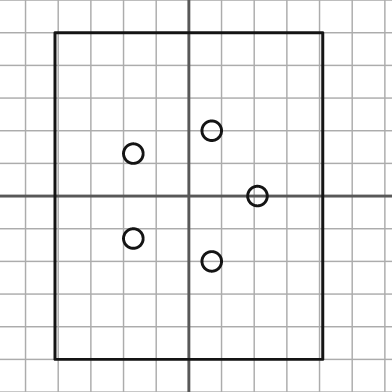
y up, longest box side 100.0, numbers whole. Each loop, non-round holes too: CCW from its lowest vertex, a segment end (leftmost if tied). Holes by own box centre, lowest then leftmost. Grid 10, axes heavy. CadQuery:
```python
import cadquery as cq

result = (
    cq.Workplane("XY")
    .moveTo(-41.0, -50.0)
    .lineTo(41.0, -50.0)
    .lineTo(41.0, 50.0)
    .lineTo(-41.0, 50.0)
    .close()
    .moveTo(7.0, -20.0)
    .circle(3.0)
    .moveTo(-17.0, -13.0)
    .circle(3.0)
    .moveTo(21.0, 0.0)
    .circle(3.0)
    .moveTo(-17.0, 13.0)
    .circle(3.0)
    .moveTo(7.0, 20.0)
    .circle(3.0)
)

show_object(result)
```